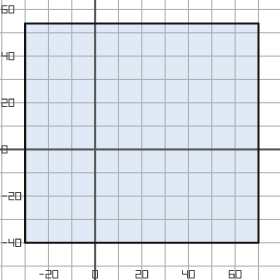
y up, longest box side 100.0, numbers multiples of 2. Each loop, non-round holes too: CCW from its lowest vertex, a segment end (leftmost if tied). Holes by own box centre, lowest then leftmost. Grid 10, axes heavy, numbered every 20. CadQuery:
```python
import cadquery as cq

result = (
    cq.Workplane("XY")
    .moveTo(-30.0, -40.0)
    .lineTo(70.0, -40.0)
    .lineTo(70.0, 54.0)
    .lineTo(-30.0, 54.0)
    .close()
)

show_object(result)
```